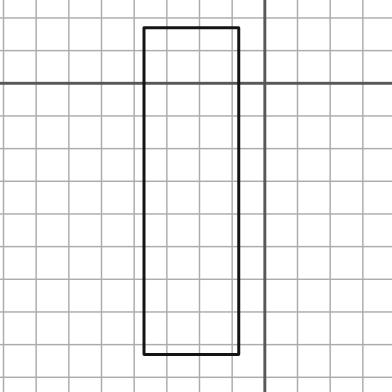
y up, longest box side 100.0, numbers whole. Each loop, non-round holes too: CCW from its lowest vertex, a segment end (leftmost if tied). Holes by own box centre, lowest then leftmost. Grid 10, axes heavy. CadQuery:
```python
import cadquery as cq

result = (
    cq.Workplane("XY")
    .moveTo(-37.0, -83.0)
    .lineTo(-8.0, -83.0)
    .lineTo(-8.0, 17.0)
    .lineTo(-37.0, 17.0)
    .close()
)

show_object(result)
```